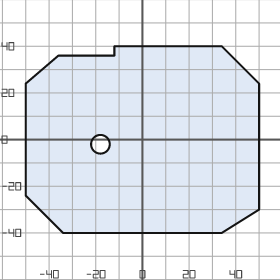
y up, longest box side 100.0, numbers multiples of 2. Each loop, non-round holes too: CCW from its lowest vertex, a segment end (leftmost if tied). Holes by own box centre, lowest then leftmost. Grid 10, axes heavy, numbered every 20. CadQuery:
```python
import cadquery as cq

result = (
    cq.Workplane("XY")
    .moveTo(-34.0, -40.0)
    .lineTo(34.0, -40.0)
    .lineTo(50.0, -30.0)
    .lineTo(50.0, 24.0)
    .lineTo(34.0, 40.0)
    .lineTo(-12.0, 40.0)
    .lineTo(-12.0, 36.0)
    .lineTo(-36.0, 36.0)
    .lineTo(-50.0, 24.0)
    .lineTo(-50.0, -24.0)
    .close()
    .moveTo(-18.0, -2.0)
    .circle(4.0)
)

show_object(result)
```